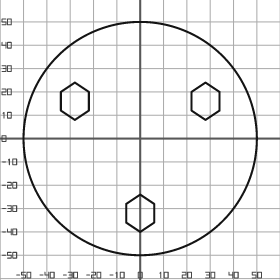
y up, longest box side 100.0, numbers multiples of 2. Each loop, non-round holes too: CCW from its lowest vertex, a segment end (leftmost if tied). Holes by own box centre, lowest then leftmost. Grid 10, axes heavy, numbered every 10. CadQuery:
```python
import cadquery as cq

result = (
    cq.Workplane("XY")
    .moveTo(0.0, 0.0)
    .circle(50.0)
    .moveTo(0.0, -40.0)
    .lineTo(6.0, -36.0)
    .lineTo(6.0, -28.0)
    .lineTo(0.0, -24.0)
    .lineTo(-6.0, -28.0)
    .lineTo(-6.0, -36.0)
    .close()
    .moveTo(-28.0, 8.0)
    .lineTo(-22.0, 12.0)
    .lineTo(-22.0, 20.0)
    .lineTo(-28.0, 24.0)
    .lineTo(-34.0, 20.0)
    .lineTo(-34.0, 12.0)
    .close()
    .moveTo(28.0, 8.0)
    .lineTo(34.0, 12.0)
    .lineTo(34.0, 20.0)
    .lineTo(28.0, 24.0)
    .lineTo(22.0, 20.0)
    .lineTo(22.0, 12.0)
    .close()
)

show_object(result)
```